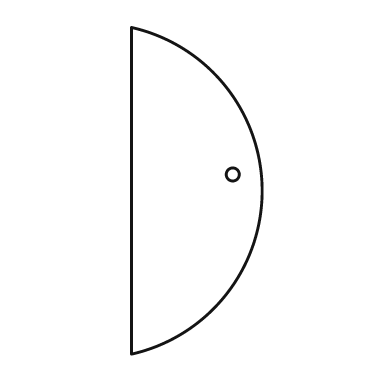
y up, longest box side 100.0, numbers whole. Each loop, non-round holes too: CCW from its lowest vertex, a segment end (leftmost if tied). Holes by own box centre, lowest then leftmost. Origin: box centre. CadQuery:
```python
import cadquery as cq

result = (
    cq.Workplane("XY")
    .moveTo(-20.0, -50.0)
    .threePointArc((20.0, 0.0), (-20.0, 50.0))
    .close()
    .moveTo(11.0, 5.0)
    .circle(2.0)
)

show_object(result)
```